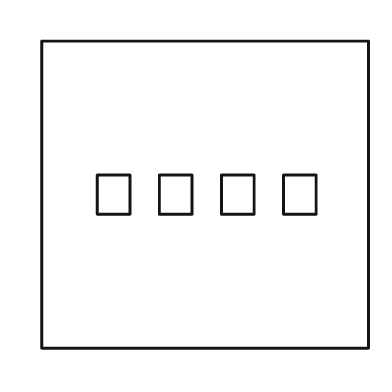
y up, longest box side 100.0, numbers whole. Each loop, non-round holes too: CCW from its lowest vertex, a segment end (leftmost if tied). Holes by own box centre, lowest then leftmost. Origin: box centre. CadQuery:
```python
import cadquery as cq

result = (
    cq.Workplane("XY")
    .moveTo(-50.0, -47.0)
    .lineTo(50.0, -47.0)
    .lineTo(50.0, 47.0)
    .lineTo(-50.0, 47.0)
    .close()
    .moveTo(-33.0, -6.0)
    .lineTo(-23.0, -6.0)
    .lineTo(-23.0, 6.0)
    .lineTo(-33.0, 6.0)
    .close()
    .moveTo(-14.0, -6.0)
    .lineTo(-4.0, -6.0)
    .lineTo(-4.0, 6.0)
    .lineTo(-14.0, 6.0)
    .close()
    .moveTo(5.0, -6.0)
    .lineTo(15.0, -6.0)
    .lineTo(15.0, 6.0)
    .lineTo(5.0, 6.0)
    .close()
    .moveTo(24.0, -6.0)
    .lineTo(34.0, -6.0)
    .lineTo(34.0, 6.0)
    .lineTo(24.0, 6.0)
    .close()
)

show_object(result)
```